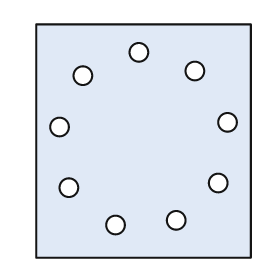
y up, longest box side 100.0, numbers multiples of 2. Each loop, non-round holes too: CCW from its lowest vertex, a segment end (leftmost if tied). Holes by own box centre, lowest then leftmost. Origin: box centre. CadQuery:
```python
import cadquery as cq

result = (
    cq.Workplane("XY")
    .moveTo(-46.0, -50.0)
    .lineTo(46.0, -50.0)
    .lineTo(46.0, 50.0)
    .lineTo(-46.0, 50.0)
    .close()
    .moveTo(-12.0, -36.0)
    .circle(4.0)
    .moveTo(14.0, -34.0)
    .circle(4.0)
    .moveTo(-32.0, -20.0)
    .circle(4.0)
    .moveTo(32.0, -18.0)
    .circle(4.0)
    .moveTo(-36.0, 6.0)
    .circle(4.0)
    .moveTo(36.0, 8.0)
    .circle(4.0)
    .moveTo(-26.0, 28.0)
    .circle(4.0)
    .moveTo(22.0, 30.0)
    .circle(4.0)
    .moveTo(-2.0, 38.0)
    .circle(4.0)
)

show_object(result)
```